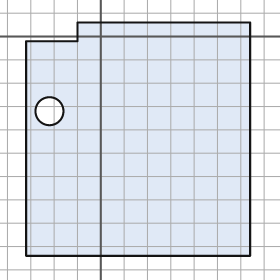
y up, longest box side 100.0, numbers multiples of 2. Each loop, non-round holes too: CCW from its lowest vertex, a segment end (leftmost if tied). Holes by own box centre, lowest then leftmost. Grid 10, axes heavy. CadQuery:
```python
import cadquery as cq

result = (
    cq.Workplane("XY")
    .moveTo(-32.0, -94.0)
    .lineTo(64.0, -94.0)
    .lineTo(64.0, 6.0)
    .lineTo(-10.0, 6.0)
    .lineTo(-10.0, -2.0)
    .lineTo(-32.0, -2.0)
    .close()
    .moveTo(-22.0, -32.0)
    .circle(6.0)
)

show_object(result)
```